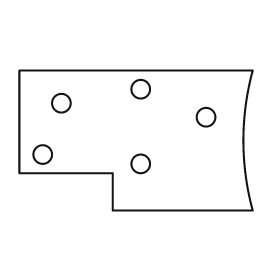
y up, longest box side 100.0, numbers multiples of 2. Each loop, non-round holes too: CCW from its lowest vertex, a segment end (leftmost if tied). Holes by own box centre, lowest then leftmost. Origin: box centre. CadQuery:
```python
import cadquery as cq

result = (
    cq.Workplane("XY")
    .moveTo(-10.0, -30.0)
    .lineTo(50.0, -30.0)
    .threePointArc((46.0, 0.0), (50.0, 30.0))
    .lineTo(-50.0, 30.0)
    .lineTo(-50.0, -14.0)
    .lineTo(-10.0, -14.0)
    .close()
    .moveTo(2.0, -10.0)
    .circle(4.0)
    .moveTo(-40.0, -6.0)
    .circle(4.0)
    .moveTo(30.0, 10.0)
    .circle(4.0)
    .moveTo(-32.0, 16.0)
    .circle(4.0)
    .moveTo(2.0, 22.0)
    .circle(4.0)
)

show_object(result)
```